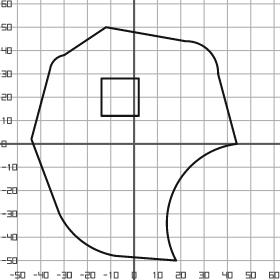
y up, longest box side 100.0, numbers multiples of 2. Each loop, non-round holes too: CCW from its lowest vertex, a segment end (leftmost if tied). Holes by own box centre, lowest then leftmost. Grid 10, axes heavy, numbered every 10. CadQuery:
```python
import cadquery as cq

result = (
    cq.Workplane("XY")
    .moveTo(18.0, -50.0)
    .threePointArc((18.0, -18.0), (44.0, 0.0))
    .lineTo(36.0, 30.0)
    .threePointArc((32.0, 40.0), (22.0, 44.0))
    .lineTo(-12.0, 50.0)
    .lineTo(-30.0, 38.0)
    .threePointArc((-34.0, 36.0), (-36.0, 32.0))
    .lineTo(-44.0, 2.0)
    .lineTo(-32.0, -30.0)
    .threePointArc((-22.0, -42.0), (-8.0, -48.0))
    .close()
    .moveTo(-14.0, 12.0)
    .lineTo(2.0, 12.0)
    .lineTo(2.0, 28.0)
    .lineTo(-14.0, 28.0)
    .close()
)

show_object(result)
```